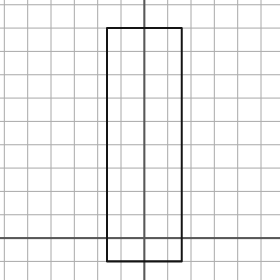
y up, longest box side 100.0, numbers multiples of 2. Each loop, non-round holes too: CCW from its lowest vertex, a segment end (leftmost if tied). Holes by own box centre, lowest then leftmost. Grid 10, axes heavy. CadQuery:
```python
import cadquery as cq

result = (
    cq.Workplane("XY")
    .moveTo(-16.0, -10.0)
    .lineTo(16.0, -10.0)
    .lineTo(16.0, 90.0)
    .lineTo(-16.0, 90.0)
    .close()
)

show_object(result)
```